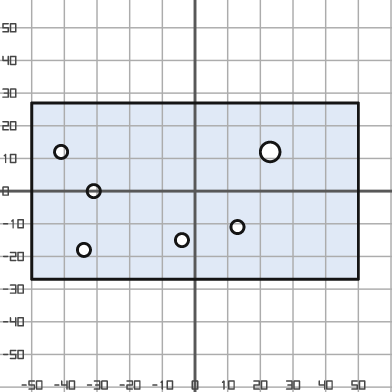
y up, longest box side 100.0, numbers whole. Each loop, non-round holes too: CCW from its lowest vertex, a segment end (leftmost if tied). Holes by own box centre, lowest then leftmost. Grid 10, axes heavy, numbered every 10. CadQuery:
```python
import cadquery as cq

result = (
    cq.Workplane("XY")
    .moveTo(-50.0, -27.0)
    .lineTo(50.0, -27.0)
    .lineTo(50.0, 27.0)
    .lineTo(-50.0, 27.0)
    .close()
    .moveTo(-34.0, -18.0)
    .circle(2.0)
    .moveTo(-4.0, -15.0)
    .circle(2.0)
    .moveTo(13.0, -11.0)
    .circle(2.0)
    .moveTo(-31.0, 0.0)
    .circle(2.0)
    .moveTo(-41.0, 12.0)
    .circle(2.0)
    .moveTo(23.0, 12.0)
    .circle(3.0)
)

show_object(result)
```